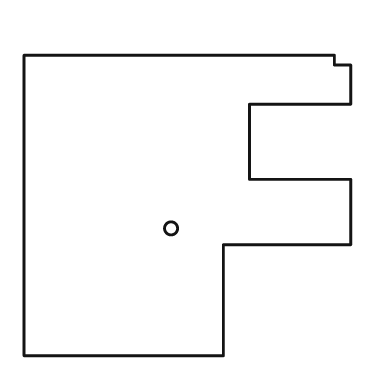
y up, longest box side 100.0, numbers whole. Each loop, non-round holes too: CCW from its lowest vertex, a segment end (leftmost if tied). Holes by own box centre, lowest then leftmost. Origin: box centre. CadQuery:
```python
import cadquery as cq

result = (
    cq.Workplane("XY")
    .moveTo(-50.0, -46.0)
    .lineTo(11.0, -46.0)
    .lineTo(11.0, -12.0)
    .lineTo(50.0, -12.0)
    .lineTo(50.0, 8.0)
    .lineTo(19.0, 8.0)
    .lineTo(19.0, 31.0)
    .lineTo(50.0, 31.0)
    .lineTo(50.0, 43.0)
    .lineTo(45.0, 43.0)
    .lineTo(45.0, 46.0)
    .lineTo(-50.0, 46.0)
    .close()
    .moveTo(-5.0, -7.0)
    .circle(2.0)
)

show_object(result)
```